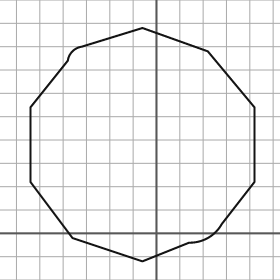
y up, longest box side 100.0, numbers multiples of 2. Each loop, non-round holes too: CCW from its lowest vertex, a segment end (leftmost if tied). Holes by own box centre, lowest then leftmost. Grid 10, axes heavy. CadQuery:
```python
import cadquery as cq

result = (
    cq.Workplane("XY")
    .moveTo(-6.0, -12.0)
    .lineTo(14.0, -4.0)
    .threePointArc((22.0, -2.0), (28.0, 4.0))
    .lineTo(42.0, 22.0)
    .lineTo(42.0, 54.0)
    .lineTo(22.0, 78.0)
    .lineTo(-6.0, 88.0)
    .lineTo(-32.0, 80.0)
    .threePointArc((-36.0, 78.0), (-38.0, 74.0))
    .lineTo(-54.0, 54.0)
    .lineTo(-54.0, 22.0)
    .lineTo(-36.0, -2.0)
    .close()
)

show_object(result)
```